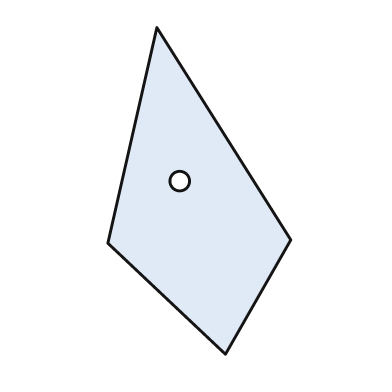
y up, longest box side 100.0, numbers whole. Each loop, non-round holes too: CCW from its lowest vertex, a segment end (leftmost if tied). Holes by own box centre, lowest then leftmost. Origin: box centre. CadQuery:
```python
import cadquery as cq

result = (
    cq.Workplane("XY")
    .moveTo(8.0, -50.0)
    .lineTo(28.0, -15.0)
    .lineTo(-13.0, 50.0)
    .lineTo(-28.0, -16.0)
    .close()
    .moveTo(-6.0, 3.0)
    .circle(3.0)
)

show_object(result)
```